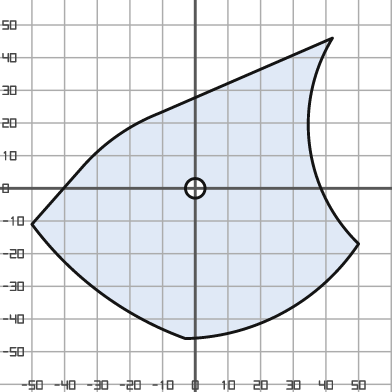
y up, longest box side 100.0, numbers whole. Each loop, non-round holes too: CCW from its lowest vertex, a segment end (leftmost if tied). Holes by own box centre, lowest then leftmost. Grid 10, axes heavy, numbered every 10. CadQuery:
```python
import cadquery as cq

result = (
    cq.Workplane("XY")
    .moveTo(-3.0, -46.0)
    .threePointArc((27.0, -38.0), (50.0, -17.0))
    .threePointArc((35.0, 13.0), (42.0, 46.0))
    .lineTo(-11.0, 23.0)
    .threePointArc((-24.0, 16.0), (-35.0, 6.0))
    .lineTo(-50.0, -11.0)
    .threePointArc((-29.0, -32.0), (-3.0, -46.0))
    .close()
    .moveTo(0.0, 0.0)
    .circle(3.0)
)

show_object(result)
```